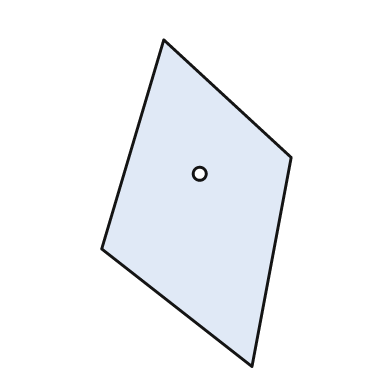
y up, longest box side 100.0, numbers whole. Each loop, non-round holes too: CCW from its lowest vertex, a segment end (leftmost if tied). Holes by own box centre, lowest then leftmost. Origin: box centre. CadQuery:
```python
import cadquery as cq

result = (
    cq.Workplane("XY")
    .moveTo(17.0, -50.0)
    .lineTo(29.0, 14.0)
    .lineTo(-10.0, 50.0)
    .lineTo(-29.0, -14.0)
    .close()
    .moveTo(1.0, 9.0)
    .circle(2.0)
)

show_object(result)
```